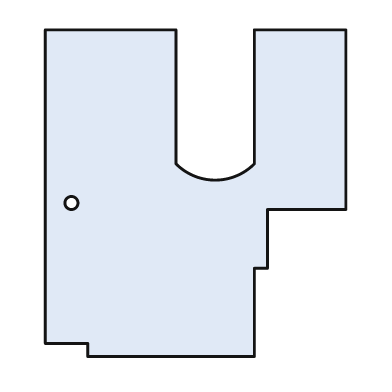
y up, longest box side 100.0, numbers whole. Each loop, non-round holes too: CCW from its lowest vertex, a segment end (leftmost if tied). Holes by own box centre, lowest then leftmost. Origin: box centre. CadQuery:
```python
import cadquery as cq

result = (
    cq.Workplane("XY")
    .moveTo(-33.0, -50.0)
    .lineTo(18.0, -50.0)
    .lineTo(18.0, -23.0)
    .lineTo(22.0, -23.0)
    .lineTo(22.0, -5.0)
    .lineTo(46.0, -5.0)
    .lineTo(46.0, 50.0)
    .lineTo(18.0, 50.0)
    .lineTo(18.0, 9.0)
    .threePointArc((6.0, 4.0), (-6.0, 9.0))
    .lineTo(-6.0, 50.0)
    .lineTo(-46.0, 50.0)
    .lineTo(-46.0, -46.0)
    .lineTo(-33.0, -46.0)
    .close()
    .moveTo(-38.0, -3.0)
    .circle(2.0)
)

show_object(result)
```